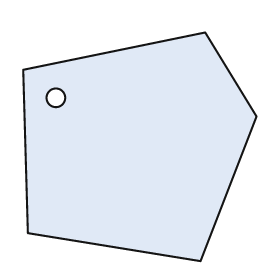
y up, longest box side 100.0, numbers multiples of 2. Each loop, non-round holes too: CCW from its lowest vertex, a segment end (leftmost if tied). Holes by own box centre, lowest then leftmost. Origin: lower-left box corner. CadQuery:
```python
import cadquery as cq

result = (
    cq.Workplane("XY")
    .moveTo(76.0, 0.0)
    .lineTo(100.0, 62.0)
    .lineTo(78.0, 98.0)
    .lineTo(0.0, 82.0)
    .lineTo(2.0, 12.0)
    .close()
    .moveTo(14.0, 70.0)
    .circle(4.0)
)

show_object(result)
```